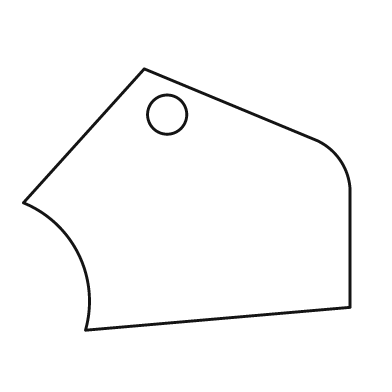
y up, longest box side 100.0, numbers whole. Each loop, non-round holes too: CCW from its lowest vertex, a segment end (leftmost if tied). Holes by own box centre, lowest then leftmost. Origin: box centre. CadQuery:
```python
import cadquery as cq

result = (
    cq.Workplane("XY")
    .moveTo(-31.0, -40.0)
    .lineTo(50.0, -33.0)
    .lineTo(50.0, 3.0)
    .threePointArc((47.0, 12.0), (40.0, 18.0))
    .lineTo(-13.0, 40.0)
    .lineTo(-50.0, -1.0)
    .threePointArc((-33.0, -17.0), (-31.0, -40.0))
    .close()
    .moveTo(-6.0, 26.0)
    .circle(6.0)
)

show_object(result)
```